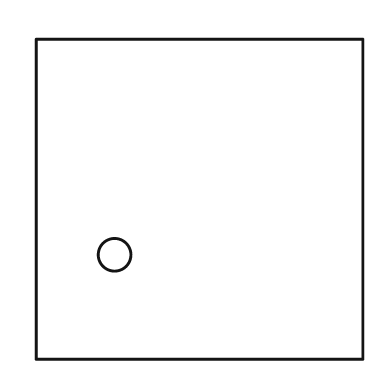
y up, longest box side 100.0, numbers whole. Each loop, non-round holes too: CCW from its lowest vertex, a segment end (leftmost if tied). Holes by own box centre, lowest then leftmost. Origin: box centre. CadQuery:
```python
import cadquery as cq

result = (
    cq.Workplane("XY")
    .moveTo(-50.0, -49.0)
    .lineTo(50.0, -49.0)
    .lineTo(50.0, 49.0)
    .lineTo(-50.0, 49.0)
    .close()
    .moveTo(-26.0, -17.0)
    .circle(5.0)
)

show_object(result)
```